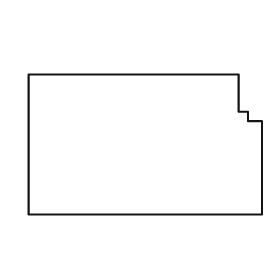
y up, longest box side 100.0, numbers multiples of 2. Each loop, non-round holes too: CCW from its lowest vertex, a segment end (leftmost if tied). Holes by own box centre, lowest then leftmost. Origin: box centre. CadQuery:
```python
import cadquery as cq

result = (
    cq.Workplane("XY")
    .moveTo(-50.0, -30.0)
    .lineTo(50.0, -30.0)
    .lineTo(50.0, 10.0)
    .lineTo(44.0, 10.0)
    .lineTo(44.0, 14.0)
    .lineTo(40.0, 14.0)
    .lineTo(40.0, 30.0)
    .lineTo(-50.0, 30.0)
    .close()
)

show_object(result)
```